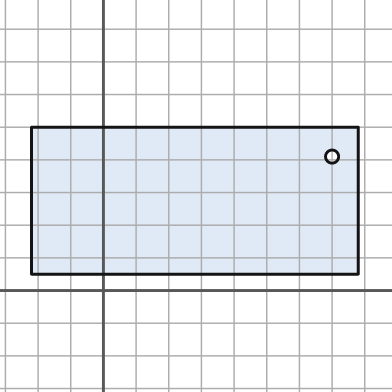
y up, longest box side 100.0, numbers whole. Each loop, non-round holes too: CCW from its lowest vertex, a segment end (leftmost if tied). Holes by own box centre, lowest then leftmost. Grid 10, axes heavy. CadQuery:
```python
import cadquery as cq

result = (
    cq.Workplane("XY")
    .moveTo(-22.0, 5.0)
    .lineTo(78.0, 5.0)
    .lineTo(78.0, 50.0)
    .lineTo(-22.0, 50.0)
    .close()
    .moveTo(70.0, 41.0)
    .circle(2.0)
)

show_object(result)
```